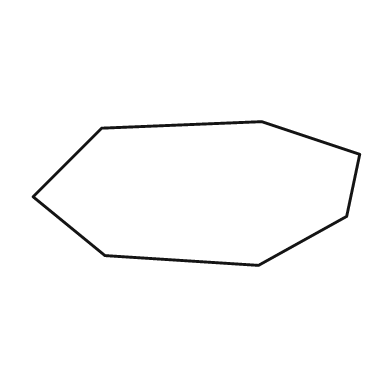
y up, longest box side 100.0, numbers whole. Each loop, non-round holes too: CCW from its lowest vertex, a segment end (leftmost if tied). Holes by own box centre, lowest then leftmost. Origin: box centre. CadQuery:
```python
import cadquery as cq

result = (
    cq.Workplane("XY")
    .moveTo(19.0, -22.0)
    .lineTo(46.0, -7.0)
    .lineTo(50.0, 12.0)
    .lineTo(20.0, 22.0)
    .lineTo(-29.0, 20.0)
    .lineTo(-50.0, -1.0)
    .lineTo(-28.0, -19.0)
    .close()
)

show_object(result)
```